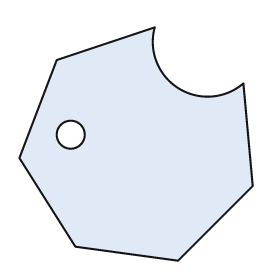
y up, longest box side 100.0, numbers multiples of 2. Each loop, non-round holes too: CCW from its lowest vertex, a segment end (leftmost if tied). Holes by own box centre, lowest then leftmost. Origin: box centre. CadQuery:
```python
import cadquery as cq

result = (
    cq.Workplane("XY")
    .moveTo(18.0, -50.0)
    .lineTo(50.0, -18.0)
    .lineTo(46.0, 26.0)
    .threePointArc((18.0, 24.0), (8.0, 50.0))
    .lineTo(-34.0, 36.0)
    .lineTo(-50.0, -6.0)
    .lineTo(-26.0, -44.0)
    .close()
    .moveTo(-28.0, 4.0)
    .circle(6.0)
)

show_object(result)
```